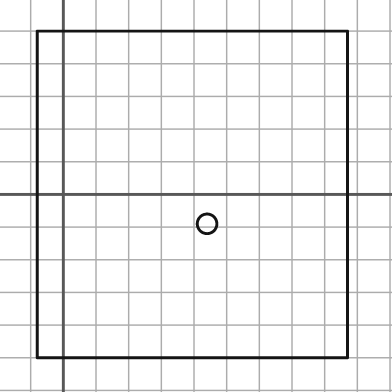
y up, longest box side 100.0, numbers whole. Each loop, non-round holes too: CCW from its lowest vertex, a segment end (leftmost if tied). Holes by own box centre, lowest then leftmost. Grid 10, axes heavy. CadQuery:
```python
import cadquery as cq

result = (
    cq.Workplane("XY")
    .moveTo(-8.0, -50.0)
    .lineTo(87.0, -50.0)
    .lineTo(87.0, 50.0)
    .lineTo(-8.0, 50.0)
    .close()
    .moveTo(44.0, -9.0)
    .circle(3.0)
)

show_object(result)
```